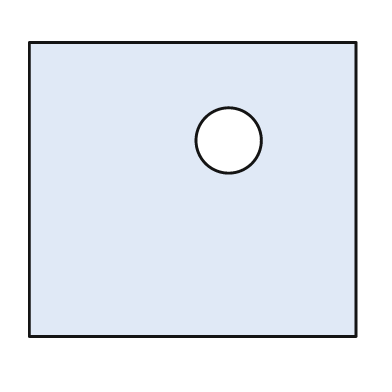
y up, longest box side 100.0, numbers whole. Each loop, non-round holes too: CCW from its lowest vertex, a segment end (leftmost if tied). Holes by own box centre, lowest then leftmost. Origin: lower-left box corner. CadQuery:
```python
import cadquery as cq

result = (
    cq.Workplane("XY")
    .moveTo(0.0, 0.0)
    .lineTo(100.0, 0.0)
    .lineTo(100.0, 90.0)
    .lineTo(0.0, 90.0)
    .close()
    .moveTo(61.0, 60.0)
    .circle(10.0)
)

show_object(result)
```